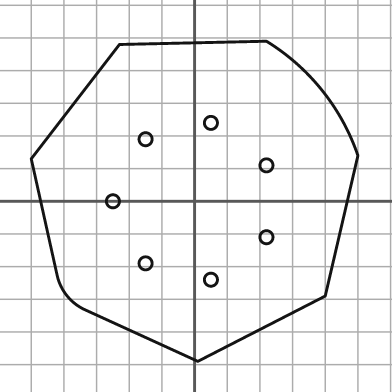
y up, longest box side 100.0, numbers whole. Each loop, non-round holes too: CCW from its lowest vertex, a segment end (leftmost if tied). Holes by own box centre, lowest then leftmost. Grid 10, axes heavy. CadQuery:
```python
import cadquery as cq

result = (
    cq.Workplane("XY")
    .moveTo(1.0, -49.0)
    .lineTo(40.0, -29.0)
    .lineTo(50.0, 14.0)
    .threePointArc((39.0, 34.0), (22.0, 49.0))
    .lineTo(-23.0, 48.0)
    .lineTo(-50.0, 13.0)
    .lineTo(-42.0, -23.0)
    .threePointArc((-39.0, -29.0), (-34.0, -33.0))
    .close()
    .moveTo(5.0, -24.0)
    .circle(2.0)
    .moveTo(-15.0, -19.0)
    .circle(2.0)
    .moveTo(22.0, -11.0)
    .circle(2.0)
    .moveTo(-25.0, 0.0)
    .circle(2.0)
    .moveTo(22.0, 11.0)
    .circle(2.0)
    .moveTo(-15.0, 19.0)
    .circle(2.0)
    .moveTo(5.0, 24.0)
    .circle(2.0)
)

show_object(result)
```